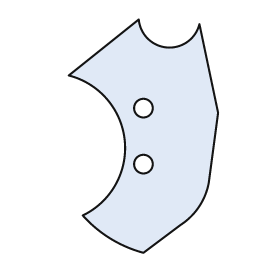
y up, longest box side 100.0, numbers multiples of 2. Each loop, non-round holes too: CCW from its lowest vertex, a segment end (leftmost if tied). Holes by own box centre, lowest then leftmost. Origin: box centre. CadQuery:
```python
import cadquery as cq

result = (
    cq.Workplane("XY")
    .moveTo(0.0, -50.0)
    .lineTo(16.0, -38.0)
    .threePointArc((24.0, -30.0), (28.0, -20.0))
    .lineTo(32.0, 10.0)
    .lineTo(24.0, 48.0)
    .threePointArc((10.0, 38.0), (-2.0, 50.0))
    .lineTo(-32.0, 26.0)
    .threePointArc((-8.0, -2.0), (-26.0, -34.0))
    .threePointArc((-14.0, -44.0), (0.0, -50.0))
    .close()
    .moveTo(0.0, -12.0)
    .circle(4.0)
    .moveTo(0.0, 12.0)
    .circle(4.0)
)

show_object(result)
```